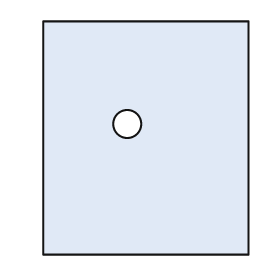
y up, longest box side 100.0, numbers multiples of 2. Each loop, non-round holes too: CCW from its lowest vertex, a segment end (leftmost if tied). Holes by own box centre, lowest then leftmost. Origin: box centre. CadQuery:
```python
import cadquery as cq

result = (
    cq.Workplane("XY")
    .moveTo(-44.0, -50.0)
    .lineTo(44.0, -50.0)
    .lineTo(44.0, 50.0)
    .lineTo(-44.0, 50.0)
    .close()
    .moveTo(-8.0, 6.0)
    .circle(6.0)
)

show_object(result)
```